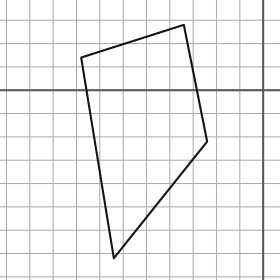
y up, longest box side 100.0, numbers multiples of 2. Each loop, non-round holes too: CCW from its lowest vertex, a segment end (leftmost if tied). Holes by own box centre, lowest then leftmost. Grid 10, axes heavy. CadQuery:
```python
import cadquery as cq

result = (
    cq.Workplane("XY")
    .moveTo(-64.0, -72.0)
    .lineTo(-24.0, -22.0)
    .lineTo(-34.0, 28.0)
    .lineTo(-78.0, 14.0)
    .close()
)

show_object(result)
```